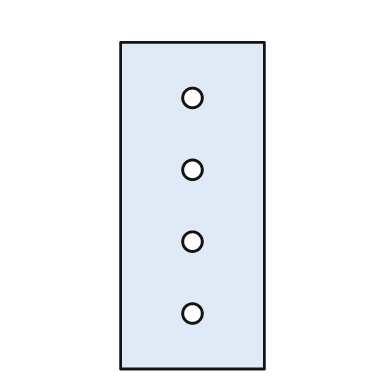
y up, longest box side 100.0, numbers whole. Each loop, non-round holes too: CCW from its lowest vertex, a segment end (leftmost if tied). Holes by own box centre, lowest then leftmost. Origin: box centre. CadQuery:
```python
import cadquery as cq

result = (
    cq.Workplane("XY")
    .moveTo(-22.0, -50.0)
    .lineTo(22.0, -50.0)
    .lineTo(22.0, 50.0)
    .lineTo(-22.0, 50.0)
    .close()
    .moveTo(0.0, -33.0)
    .circle(3.0)
    .moveTo(0.0, -11.0)
    .circle(3.0)
    .moveTo(0.0, 11.0)
    .circle(3.0)
    .moveTo(0.0, 33.0)
    .circle(3.0)
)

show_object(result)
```